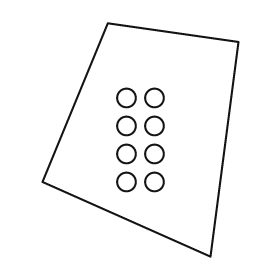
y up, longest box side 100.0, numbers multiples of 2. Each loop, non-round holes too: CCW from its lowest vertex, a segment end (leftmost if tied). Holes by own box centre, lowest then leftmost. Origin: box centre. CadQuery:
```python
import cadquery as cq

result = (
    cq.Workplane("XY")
    .moveTo(30.0, -50.0)
    .lineTo(42.0, 42.0)
    .lineTo(-14.0, 50.0)
    .lineTo(-42.0, -18.0)
    .close()
    .moveTo(-6.0, -18.0)
    .circle(4.0)
    .moveTo(6.0, -18.0)
    .circle(4.0)
    .moveTo(-6.0, -6.0)
    .circle(4.0)
    .moveTo(6.0, -6.0)
    .circle(4.0)
    .moveTo(-6.0, 6.0)
    .circle(4.0)
    .moveTo(6.0, 6.0)
    .circle(4.0)
    .moveTo(-6.0, 18.0)
    .circle(4.0)
    .moveTo(6.0, 18.0)
    .circle(4.0)
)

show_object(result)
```